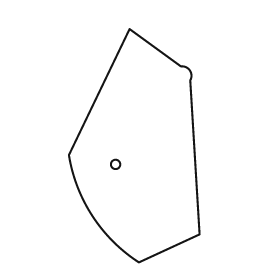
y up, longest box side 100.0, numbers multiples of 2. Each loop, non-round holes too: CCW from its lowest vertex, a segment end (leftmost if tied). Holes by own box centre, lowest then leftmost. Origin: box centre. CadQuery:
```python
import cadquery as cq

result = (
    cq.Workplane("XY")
    .moveTo(2.0, -50.0)
    .lineTo(28.0, -38.0)
    .lineTo(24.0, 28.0)
    .threePointArc((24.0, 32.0), (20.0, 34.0))
    .lineTo(-2.0, 50.0)
    .lineTo(-28.0, -4.0)
    .threePointArc((-18.0, -30.0), (2.0, -50.0))
    .close()
    .moveTo(-8.0, -8.0)
    .circle(2.0)
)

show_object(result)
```